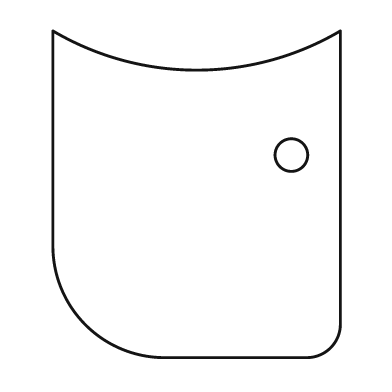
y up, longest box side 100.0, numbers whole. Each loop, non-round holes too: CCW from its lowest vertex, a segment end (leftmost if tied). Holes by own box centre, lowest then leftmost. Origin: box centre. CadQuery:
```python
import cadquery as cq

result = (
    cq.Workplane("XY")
    .moveTo(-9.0, -50.0)
    .lineTo(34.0, -50.0)
    .threePointArc((41.0, -47.0), (44.0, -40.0))
    .lineTo(44.0, 50.0)
    .threePointArc((0.0, 38.0), (-44.0, 50.0))
    .lineTo(-44.0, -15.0)
    .threePointArc((-34.0, -40.0), (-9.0, -50.0))
    .close()
    .moveTo(29.0, 12.0)
    .circle(5.0)
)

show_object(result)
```